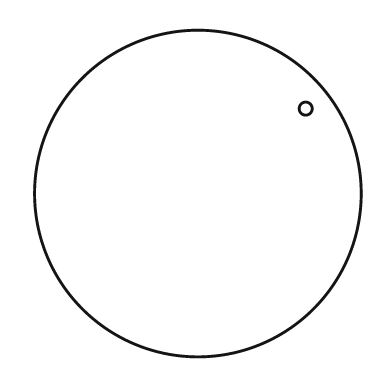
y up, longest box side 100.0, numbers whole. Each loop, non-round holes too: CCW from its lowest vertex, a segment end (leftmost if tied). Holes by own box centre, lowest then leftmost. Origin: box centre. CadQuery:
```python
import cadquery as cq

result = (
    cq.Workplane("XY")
    .moveTo(0.0, 0.0)
    .circle(50.0)
    .moveTo(33.0, 26.0)
    .circle(2.0)
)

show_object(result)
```